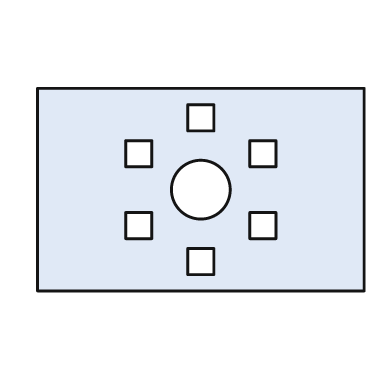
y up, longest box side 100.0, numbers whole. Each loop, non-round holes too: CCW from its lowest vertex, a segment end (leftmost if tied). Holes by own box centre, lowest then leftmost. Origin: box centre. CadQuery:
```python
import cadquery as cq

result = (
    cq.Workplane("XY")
    .moveTo(-50.0, -31.0)
    .lineTo(50.0, -31.0)
    .lineTo(50.0, 31.0)
    .lineTo(-50.0, 31.0)
    .close()
    .moveTo(-4.0, -26.0)
    .lineTo(4.0, -26.0)
    .lineTo(4.0, -18.0)
    .lineTo(-4.0, -18.0)
    .close()
    .moveTo(-23.0, -15.0)
    .lineTo(-15.0, -15.0)
    .lineTo(-15.0, -7.0)
    .lineTo(-23.0, -7.0)
    .close()
    .moveTo(15.0, -15.0)
    .lineTo(23.0, -15.0)
    .lineTo(23.0, -7.0)
    .lineTo(15.0, -7.0)
    .close()
    .moveTo(0.0, 0.0)
    .circle(9.0)
    .moveTo(-23.0, 7.0)
    .lineTo(-15.0, 7.0)
    .lineTo(-15.0, 15.0)
    .lineTo(-23.0, 15.0)
    .close()
    .moveTo(15.0, 7.0)
    .lineTo(23.0, 7.0)
    .lineTo(23.0, 15.0)
    .lineTo(15.0, 15.0)
    .close()
    .moveTo(-4.0, 18.0)
    .lineTo(4.0, 18.0)
    .lineTo(4.0, 26.0)
    .lineTo(-4.0, 26.0)
    .close()
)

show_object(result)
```